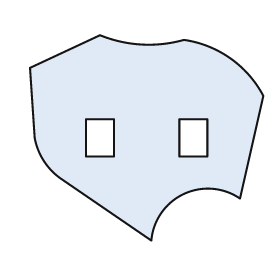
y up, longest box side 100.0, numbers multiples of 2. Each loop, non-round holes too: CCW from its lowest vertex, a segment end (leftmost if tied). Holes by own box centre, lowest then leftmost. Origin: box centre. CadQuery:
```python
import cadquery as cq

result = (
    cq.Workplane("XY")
    .moveTo(2.0, -44.0)
    .threePointArc((16.0, -24.0), (40.0, -26.0))
    .lineTo(50.0, 18.0)
    .threePointArc((36.0, 34.0), (16.0, 42.0))
    .threePointArc((-2.0, 40.0), (-20.0, 44.0))
    .lineTo(-50.0, 30.0)
    .lineTo(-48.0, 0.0)
    .threePointArc((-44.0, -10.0), (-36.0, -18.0))
    .close()
    .moveTo(-26.0, -8.0)
    .lineTo(-14.0, -8.0)
    .lineTo(-14.0, 8.0)
    .lineTo(-26.0, 8.0)
    .close()
    .moveTo(14.0, -8.0)
    .lineTo(26.0, -8.0)
    .lineTo(26.0, 8.0)
    .lineTo(14.0, 8.0)
    .close()
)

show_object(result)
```